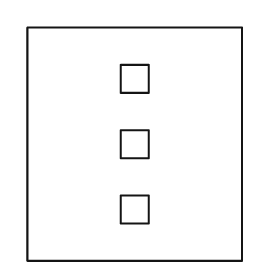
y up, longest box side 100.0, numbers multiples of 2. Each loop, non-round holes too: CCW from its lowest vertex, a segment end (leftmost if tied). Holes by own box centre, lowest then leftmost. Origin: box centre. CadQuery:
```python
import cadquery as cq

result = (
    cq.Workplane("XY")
    .moveTo(-46.0, -50.0)
    .lineTo(46.0, -50.0)
    .lineTo(46.0, 50.0)
    .lineTo(-46.0, 50.0)
    .close()
    .moveTo(-6.0, -34.0)
    .lineTo(6.0, -34.0)
    .lineTo(6.0, -22.0)
    .lineTo(-6.0, -22.0)
    .close()
    .moveTo(-6.0, -6.0)
    .lineTo(6.0, -6.0)
    .lineTo(6.0, 6.0)
    .lineTo(-6.0, 6.0)
    .close()
    .moveTo(-6.0, 22.0)
    .lineTo(6.0, 22.0)
    .lineTo(6.0, 34.0)
    .lineTo(-6.0, 34.0)
    .close()
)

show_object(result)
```